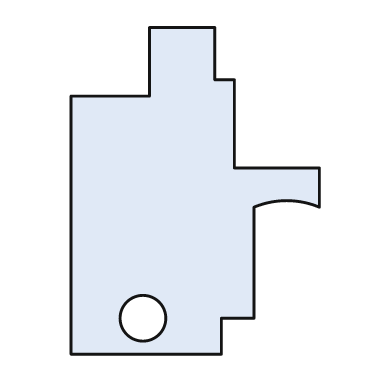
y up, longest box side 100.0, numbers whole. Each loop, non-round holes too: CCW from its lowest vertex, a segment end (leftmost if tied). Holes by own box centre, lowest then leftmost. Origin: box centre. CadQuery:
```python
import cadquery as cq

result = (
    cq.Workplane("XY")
    .moveTo(-38.0, -50.0)
    .lineTo(8.0, -50.0)
    .lineTo(8.0, -39.0)
    .lineTo(18.0, -39.0)
    .lineTo(18.0, -5.0)
    .threePointArc((28.0, -3.0), (38.0, -5.0))
    .lineTo(38.0, 7.0)
    .lineTo(12.0, 7.0)
    .lineTo(12.0, 34.0)
    .lineTo(6.0, 34.0)
    .lineTo(6.0, 50.0)
    .lineTo(-14.0, 50.0)
    .lineTo(-14.0, 29.0)
    .lineTo(-38.0, 29.0)
    .close()
    .moveTo(-16.0, -39.0)
    .circle(7.0)
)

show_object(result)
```